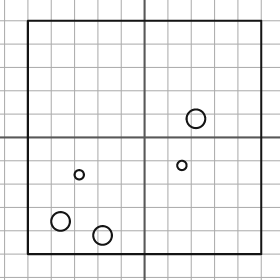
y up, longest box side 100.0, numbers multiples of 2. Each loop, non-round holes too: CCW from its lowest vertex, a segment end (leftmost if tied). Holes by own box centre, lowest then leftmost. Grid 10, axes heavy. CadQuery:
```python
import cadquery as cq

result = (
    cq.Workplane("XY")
    .moveTo(-50.0, -50.0)
    .lineTo(50.0, -50.0)
    .lineTo(50.0, 50.0)
    .lineTo(-50.0, 50.0)
    .close()
    .moveTo(-18.0, -42.0)
    .circle(4.0)
    .moveTo(-36.0, -36.0)
    .circle(4.0)
    .moveTo(-28.0, -16.0)
    .circle(2.0)
    .moveTo(16.0, -12.0)
    .circle(2.0)
    .moveTo(22.0, 8.0)
    .circle(4.0)
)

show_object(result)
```